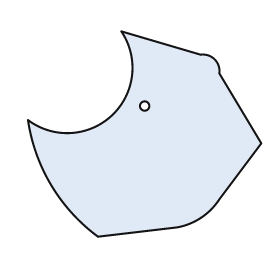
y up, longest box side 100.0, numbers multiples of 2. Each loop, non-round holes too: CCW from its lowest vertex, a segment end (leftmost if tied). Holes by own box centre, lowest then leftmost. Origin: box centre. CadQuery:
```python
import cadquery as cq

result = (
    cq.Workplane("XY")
    .moveTo(-20.0, -44.0)
    .lineTo(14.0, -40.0)
    .threePointArc((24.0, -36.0), (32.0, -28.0))
    .lineTo(50.0, -4.0)
    .lineTo(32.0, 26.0)
    .threePointArc((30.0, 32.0), (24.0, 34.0))
    .lineTo(-10.0, 44.0)
    .threePointArc((-14.0, 8.0), (-50.0, 6.0))
    .threePointArc((-40.0, -22.0), (-20.0, -44.0))
    .close()
    .moveTo(0.0, 12.0)
    .circle(2.0)
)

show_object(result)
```